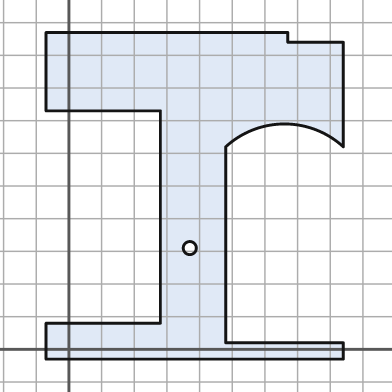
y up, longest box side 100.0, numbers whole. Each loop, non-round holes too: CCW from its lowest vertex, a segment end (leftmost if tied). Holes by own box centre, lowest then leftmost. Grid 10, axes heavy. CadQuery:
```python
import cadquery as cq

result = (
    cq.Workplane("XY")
    .moveTo(-7.0, -3.0)
    .lineTo(84.0, -3.0)
    .lineTo(84.0, 2.0)
    .lineTo(48.0, 2.0)
    .lineTo(48.0, 62.0)
    .threePointArc((66.0, 69.0), (84.0, 62.0))
    .lineTo(84.0, 94.0)
    .lineTo(67.0, 94.0)
    .lineTo(67.0, 97.0)
    .lineTo(-7.0, 97.0)
    .lineTo(-7.0, 73.0)
    .lineTo(28.0, 73.0)
    .lineTo(28.0, 8.0)
    .lineTo(-7.0, 8.0)
    .close()
    .moveTo(37.0, 31.0)
    .circle(2.0)
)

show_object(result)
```